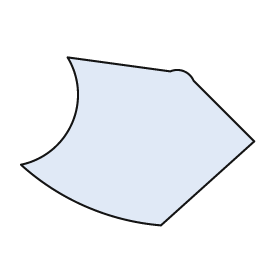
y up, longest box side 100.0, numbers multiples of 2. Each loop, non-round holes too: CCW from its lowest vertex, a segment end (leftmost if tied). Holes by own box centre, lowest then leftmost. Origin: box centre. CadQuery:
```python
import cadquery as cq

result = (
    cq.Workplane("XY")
    .moveTo(10.0, -36.0)
    .lineTo(50.0, 0.0)
    .lineTo(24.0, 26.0)
    .threePointArc((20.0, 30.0), (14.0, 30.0))
    .lineTo(-30.0, 36.0)
    .threePointArc((-28.0, 8.0), (-50.0, -10.0))
    .threePointArc((-22.0, -28.0), (10.0, -36.0))
    .close()
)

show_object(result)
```